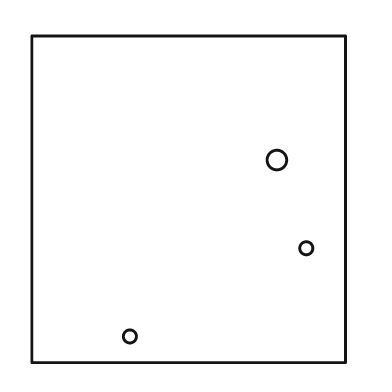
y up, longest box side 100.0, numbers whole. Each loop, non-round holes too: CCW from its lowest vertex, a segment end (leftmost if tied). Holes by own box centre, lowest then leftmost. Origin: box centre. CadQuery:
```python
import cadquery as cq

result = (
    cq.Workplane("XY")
    .moveTo(-48.0, -50.0)
    .lineTo(48.0, -50.0)
    .lineTo(48.0, 50.0)
    .lineTo(-48.0, 50.0)
    .close()
    .moveTo(-18.0, -42.0)
    .circle(2.0)
    .moveTo(36.0, -15.0)
    .circle(2.0)
    .moveTo(27.0, 12.0)
    .circle(3.0)
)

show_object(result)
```